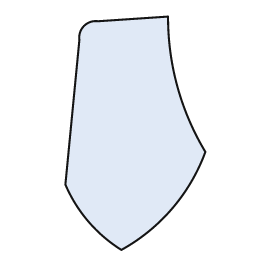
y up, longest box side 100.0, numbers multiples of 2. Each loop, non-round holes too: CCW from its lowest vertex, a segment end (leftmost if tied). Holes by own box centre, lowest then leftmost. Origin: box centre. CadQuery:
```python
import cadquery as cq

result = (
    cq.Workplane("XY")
    .moveTo(-6.0, -50.0)
    .threePointArc((16.0, -32.0), (30.0, -8.0))
    .threePointArc((18.0, 20.0), (14.0, 50.0))
    .lineTo(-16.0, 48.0)
    .threePointArc((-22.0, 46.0), (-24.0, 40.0))
    .lineTo(-30.0, -22.0)
    .threePointArc((-20.0, -38.0), (-6.0, -50.0))
    .close()
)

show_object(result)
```